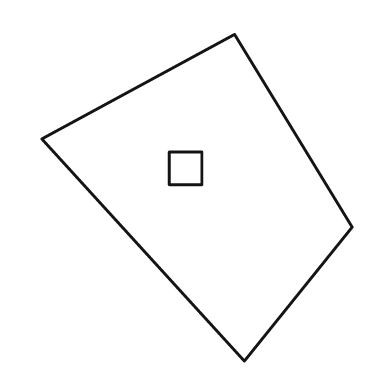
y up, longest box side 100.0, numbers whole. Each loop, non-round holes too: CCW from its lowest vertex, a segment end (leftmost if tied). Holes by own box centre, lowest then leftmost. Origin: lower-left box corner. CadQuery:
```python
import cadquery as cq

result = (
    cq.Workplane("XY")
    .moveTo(62.0, 0.0)
    .lineTo(95.0, 41.0)
    .lineTo(59.0, 100.0)
    .lineTo(0.0, 68.0)
    .close()
    .moveTo(39.0, 54.0)
    .lineTo(49.0, 54.0)
    .lineTo(49.0, 64.0)
    .lineTo(39.0, 64.0)
    .close()
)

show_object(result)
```